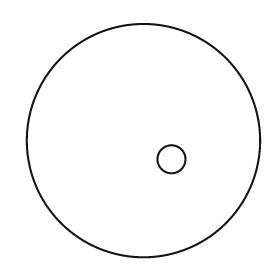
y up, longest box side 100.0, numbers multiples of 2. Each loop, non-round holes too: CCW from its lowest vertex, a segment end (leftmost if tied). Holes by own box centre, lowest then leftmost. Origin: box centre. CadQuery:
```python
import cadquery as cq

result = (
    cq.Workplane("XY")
    .moveTo(0.0, 0.0)
    .circle(50.0)
    .moveTo(12.0, -8.0)
    .circle(6.0)
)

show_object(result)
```